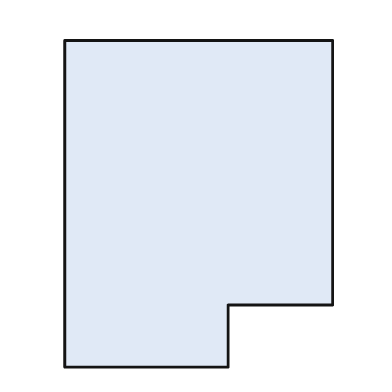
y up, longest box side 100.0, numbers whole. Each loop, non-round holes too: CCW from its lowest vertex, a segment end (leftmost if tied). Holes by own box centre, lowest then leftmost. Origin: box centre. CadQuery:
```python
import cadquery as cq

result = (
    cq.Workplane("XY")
    .moveTo(-41.0, -50.0)
    .lineTo(9.0, -50.0)
    .lineTo(9.0, -31.0)
    .lineTo(41.0, -31.0)
    .lineTo(41.0, 50.0)
    .lineTo(-41.0, 50.0)
    .close()
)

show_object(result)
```